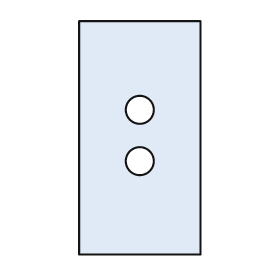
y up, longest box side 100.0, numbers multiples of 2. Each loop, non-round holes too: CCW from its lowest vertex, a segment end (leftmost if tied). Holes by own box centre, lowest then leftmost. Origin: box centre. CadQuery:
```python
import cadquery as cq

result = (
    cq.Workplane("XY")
    .moveTo(-26.0, -50.0)
    .lineTo(26.0, -50.0)
    .lineTo(26.0, 50.0)
    .lineTo(-26.0, 50.0)
    .close()
    .moveTo(0.0, -10.0)
    .circle(6.0)
    .moveTo(0.0, 12.0)
    .circle(6.0)
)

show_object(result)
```